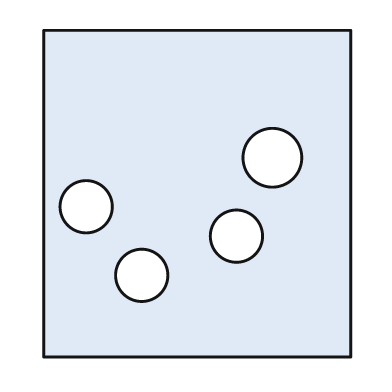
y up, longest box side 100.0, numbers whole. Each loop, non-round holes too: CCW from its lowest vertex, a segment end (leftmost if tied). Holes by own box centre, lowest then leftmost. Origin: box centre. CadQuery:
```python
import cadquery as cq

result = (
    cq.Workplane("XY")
    .moveTo(-47.0, -50.0)
    .lineTo(47.0, -50.0)
    .lineTo(47.0, 50.0)
    .lineTo(-47.0, 50.0)
    .close()
    .moveTo(-17.0, -25.0)
    .circle(8.0)
    .moveTo(12.0, -13.0)
    .circle(8.0)
    .moveTo(-34.0, -4.0)
    .circle(8.0)
    .moveTo(23.0, 11.0)
    .circle(9.0)
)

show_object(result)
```